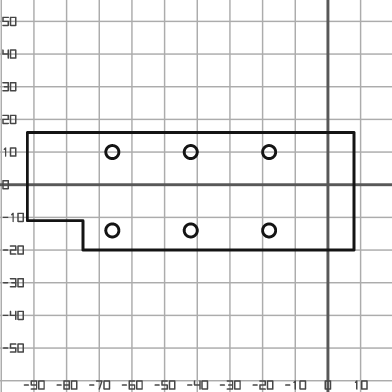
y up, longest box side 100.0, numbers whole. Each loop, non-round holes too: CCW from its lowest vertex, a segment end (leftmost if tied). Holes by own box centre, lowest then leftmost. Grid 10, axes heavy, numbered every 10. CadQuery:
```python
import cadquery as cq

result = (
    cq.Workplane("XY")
    .moveTo(-75.0, -20.0)
    .lineTo(8.0, -20.0)
    .lineTo(8.0, 16.0)
    .lineTo(-92.0, 16.0)
    .lineTo(-92.0, -11.0)
    .lineTo(-75.0, -11.0)
    .close()
    .moveTo(-66.0, -14.0)
    .circle(2.0)
    .moveTo(-42.0, -14.0)
    .circle(2.0)
    .moveTo(-18.0, -14.0)
    .circle(2.0)
    .moveTo(-66.0, 10.0)
    .circle(2.0)
    .moveTo(-42.0, 10.0)
    .circle(2.0)
    .moveTo(-18.0, 10.0)
    .circle(2.0)
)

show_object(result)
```